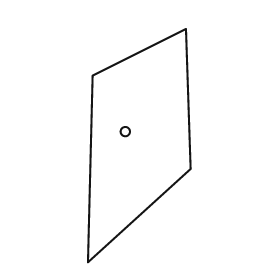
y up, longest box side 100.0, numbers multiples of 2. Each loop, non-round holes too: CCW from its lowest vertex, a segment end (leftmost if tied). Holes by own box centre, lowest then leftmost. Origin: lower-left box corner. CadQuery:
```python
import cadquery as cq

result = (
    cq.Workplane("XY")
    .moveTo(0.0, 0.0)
    .lineTo(44.0, 40.0)
    .lineTo(42.0, 100.0)
    .lineTo(2.0, 80.0)
    .close()
    .moveTo(16.0, 56.0)
    .circle(2.0)
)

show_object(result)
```